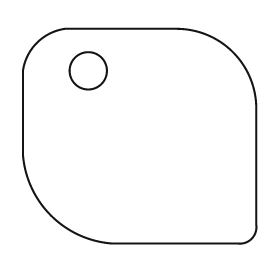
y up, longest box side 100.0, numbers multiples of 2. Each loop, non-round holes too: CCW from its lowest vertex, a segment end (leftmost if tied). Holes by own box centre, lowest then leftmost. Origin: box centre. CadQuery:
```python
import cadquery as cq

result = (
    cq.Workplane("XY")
    .moveTo(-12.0, -46.0)
    .lineTo(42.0, -46.0)
    .threePointArc((48.0, -44.0), (50.0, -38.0))
    .lineTo(50.0, 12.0)
    .threePointArc((40.0, 36.0), (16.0, 46.0))
    .lineTo(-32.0, 46.0)
    .threePointArc((-44.0, 40.0), (-50.0, 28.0))
    .lineTo(-50.0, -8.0)
    .threePointArc((-38.0, -34.0), (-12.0, -46.0))
    .close()
    .moveTo(-22.0, 28.0)
    .circle(8.0)
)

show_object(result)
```